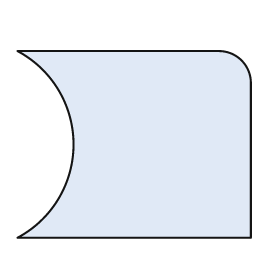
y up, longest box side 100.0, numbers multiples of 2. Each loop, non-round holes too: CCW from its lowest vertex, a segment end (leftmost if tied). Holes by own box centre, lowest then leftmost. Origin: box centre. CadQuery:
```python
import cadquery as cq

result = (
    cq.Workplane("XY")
    .moveTo(-50.0, -40.0)
    .lineTo(50.0, -40.0)
    .lineTo(50.0, 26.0)
    .threePointArc((46.0, 36.0), (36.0, 40.0))
    .lineTo(-50.0, 40.0)
    .threePointArc((-26.0, 0.0), (-50.0, -40.0))
    .close()
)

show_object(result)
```